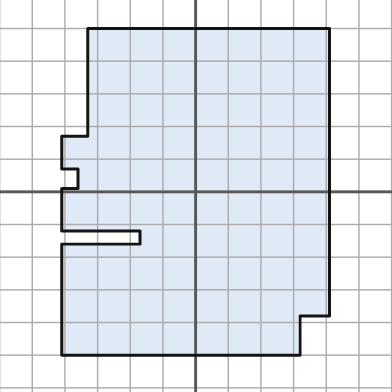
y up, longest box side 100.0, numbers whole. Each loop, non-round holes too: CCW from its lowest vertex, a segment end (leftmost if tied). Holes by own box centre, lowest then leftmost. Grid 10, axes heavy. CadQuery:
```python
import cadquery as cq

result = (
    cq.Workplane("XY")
    .moveTo(-41.0, -50.0)
    .lineTo(32.0, -50.0)
    .lineTo(32.0, -38.0)
    .lineTo(41.0, -38.0)
    .lineTo(41.0, 50.0)
    .lineTo(-33.0, 50.0)
    .lineTo(-33.0, 17.0)
    .lineTo(-41.0, 17.0)
    .lineTo(-41.0, 7.0)
    .lineTo(-36.0, 7.0)
    .lineTo(-36.0, 1.0)
    .lineTo(-41.0, 1.0)
    .lineTo(-41.0, -12.0)
    .lineTo(-17.0, -12.0)
    .lineTo(-17.0, -16.0)
    .lineTo(-41.0, -16.0)
    .close()
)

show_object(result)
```